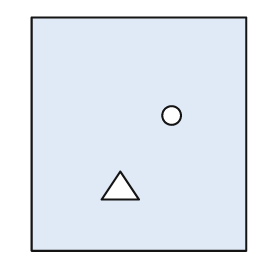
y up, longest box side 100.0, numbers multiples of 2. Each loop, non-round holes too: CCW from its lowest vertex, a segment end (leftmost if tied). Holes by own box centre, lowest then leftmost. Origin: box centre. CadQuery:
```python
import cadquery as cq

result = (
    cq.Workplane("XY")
    .moveTo(-46.0, -50.0)
    .lineTo(46.0, -50.0)
    .lineTo(46.0, 50.0)
    .lineTo(-46.0, 50.0)
    .close()
    .moveTo(-16.0, -28.0)
    .lineTo(0.0, -28.0)
    .lineTo(-8.0, -16.0)
    .close()
    .moveTo(14.0, 8.0)
    .circle(4.0)
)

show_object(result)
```